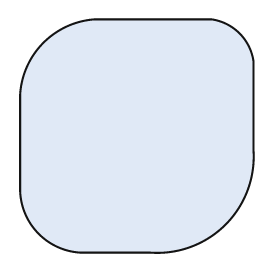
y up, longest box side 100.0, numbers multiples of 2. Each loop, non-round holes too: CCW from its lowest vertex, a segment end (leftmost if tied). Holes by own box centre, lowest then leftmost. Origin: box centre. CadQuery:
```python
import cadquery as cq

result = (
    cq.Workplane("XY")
    .moveTo(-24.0, -50.0)
    .lineTo(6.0, -50.0)
    .threePointArc((38.0, -38.0), (50.0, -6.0))
    .lineTo(50.0, 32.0)
    .threePointArc((44.0, 44.0), (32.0, 50.0))
    .lineTo(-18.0, 50.0)
    .threePointArc((-40.0, 40.0), (-50.0, 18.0))
    .lineTo(-50.0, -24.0)
    .threePointArc((-42.0, -42.0), (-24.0, -50.0))
    .close()
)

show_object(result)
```